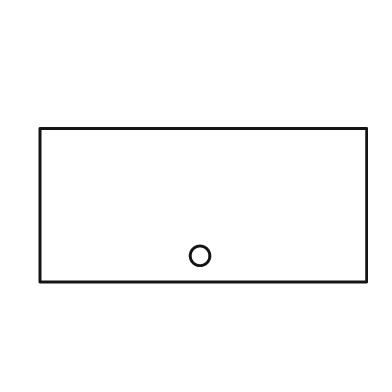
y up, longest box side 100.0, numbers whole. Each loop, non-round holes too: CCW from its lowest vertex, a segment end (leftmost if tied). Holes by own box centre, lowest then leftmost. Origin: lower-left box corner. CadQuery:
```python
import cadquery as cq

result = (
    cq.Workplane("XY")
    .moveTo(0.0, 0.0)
    .lineTo(100.0, 0.0)
    .lineTo(100.0, 47.0)
    .lineTo(0.0, 47.0)
    .close()
    .moveTo(49.0, 8.0)
    .circle(3.0)
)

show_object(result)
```